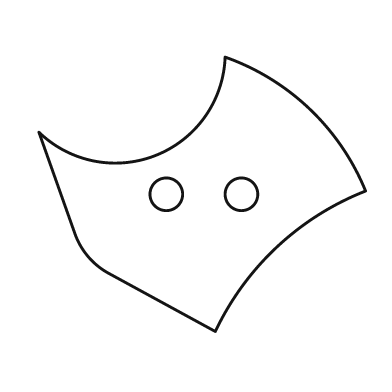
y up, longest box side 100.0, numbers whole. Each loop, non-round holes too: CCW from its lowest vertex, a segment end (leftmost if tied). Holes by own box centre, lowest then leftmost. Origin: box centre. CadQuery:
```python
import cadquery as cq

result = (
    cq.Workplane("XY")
    .moveTo(4.0, -42.0)
    .threePointArc((23.0, -16.0), (50.0, 1.0))
    .threePointArc((33.0, 26.0), (7.0, 42.0))
    .threePointArc((-14.0, 12.0), (-50.0, 19.0))
    .lineTo(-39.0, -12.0)
    .threePointArc((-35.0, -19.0), (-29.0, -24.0))
    .close()
    .moveTo(-11.0, 0.0)
    .circle(5.0)
    .moveTo(12.0, 0.0)
    .circle(5.0)
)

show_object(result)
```